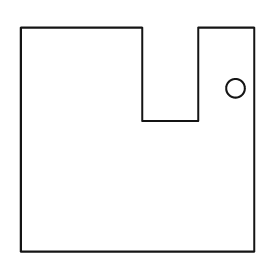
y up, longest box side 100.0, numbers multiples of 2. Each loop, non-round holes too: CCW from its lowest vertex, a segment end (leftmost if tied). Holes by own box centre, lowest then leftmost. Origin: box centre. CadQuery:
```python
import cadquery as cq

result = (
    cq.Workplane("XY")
    .moveTo(-50.0, -48.0)
    .lineTo(50.0, -48.0)
    .lineTo(50.0, 48.0)
    .lineTo(26.0, 48.0)
    .lineTo(26.0, 8.0)
    .lineTo(2.0, 8.0)
    .lineTo(2.0, 48.0)
    .lineTo(-50.0, 48.0)
    .close()
    .moveTo(42.0, 22.0)
    .circle(4.0)
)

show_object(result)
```